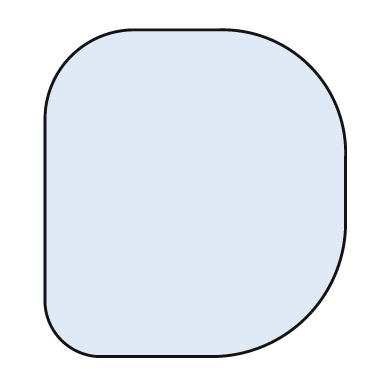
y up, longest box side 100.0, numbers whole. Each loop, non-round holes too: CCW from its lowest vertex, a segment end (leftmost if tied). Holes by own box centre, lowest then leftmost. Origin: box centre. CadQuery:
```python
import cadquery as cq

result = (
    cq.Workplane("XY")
    .moveTo(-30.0, -50.0)
    .lineTo(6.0, -50.0)
    .threePointArc((34.0, -38.0), (46.0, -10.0))
    .lineTo(46.0, 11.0)
    .threePointArc((35.0, 39.0), (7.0, 50.0))
    .lineTo(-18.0, 50.0)
    .threePointArc((-38.0, 42.0), (-46.0, 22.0))
    .lineTo(-46.0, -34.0)
    .threePointArc((-41.0, -45.0), (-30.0, -50.0))
    .close()
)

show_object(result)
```